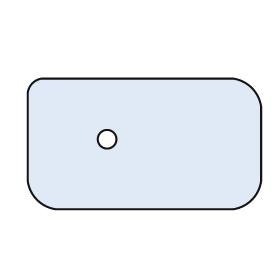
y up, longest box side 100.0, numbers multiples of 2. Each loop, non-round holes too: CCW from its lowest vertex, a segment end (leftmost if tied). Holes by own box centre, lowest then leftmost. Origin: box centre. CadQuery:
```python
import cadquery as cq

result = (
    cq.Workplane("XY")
    .moveTo(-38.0, -28.0)
    .lineTo(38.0, -28.0)
    .threePointArc((46.0, -24.0), (50.0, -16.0))
    .lineTo(50.0, 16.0)
    .threePointArc((46.0, 24.0), (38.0, 28.0))
    .lineTo(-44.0, 28.0)
    .threePointArc((-48.0, 26.0), (-50.0, 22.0))
    .lineTo(-50.0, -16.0)
    .threePointArc((-46.0, -24.0), (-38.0, -28.0))
    .close()
    .moveTo(-16.0, 2.0)
    .circle(4.0)
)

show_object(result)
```